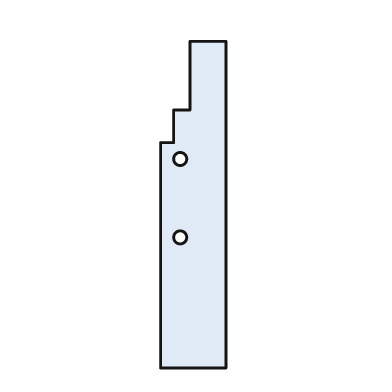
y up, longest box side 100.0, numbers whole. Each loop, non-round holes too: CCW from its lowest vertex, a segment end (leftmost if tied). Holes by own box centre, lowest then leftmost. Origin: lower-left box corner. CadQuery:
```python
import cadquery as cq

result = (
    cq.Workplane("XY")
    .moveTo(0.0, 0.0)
    .lineTo(20.0, 0.0)
    .lineTo(20.0, 100.0)
    .lineTo(9.0, 100.0)
    .lineTo(9.0, 79.0)
    .lineTo(4.0, 79.0)
    .lineTo(4.0, 69.0)
    .lineTo(0.0, 69.0)
    .close()
    .moveTo(6.0, 40.0)
    .circle(2.0)
    .moveTo(6.0, 64.0)
    .circle(2.0)
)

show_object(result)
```